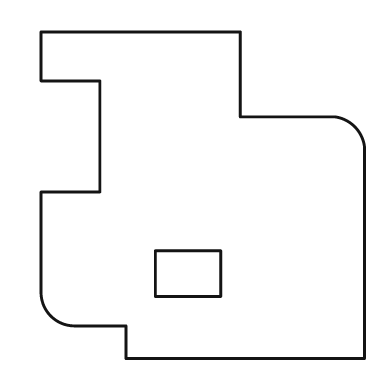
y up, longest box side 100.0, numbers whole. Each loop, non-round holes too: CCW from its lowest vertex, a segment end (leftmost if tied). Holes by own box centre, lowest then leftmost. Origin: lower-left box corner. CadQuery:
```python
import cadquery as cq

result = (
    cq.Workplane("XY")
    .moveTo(26.0, 0.0)
    .lineTo(99.0, 0.0)
    .lineTo(99.0, 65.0)
    .threePointArc((96.0, 71.0), (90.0, 74.0))
    .lineTo(61.0, 74.0)
    .lineTo(61.0, 100.0)
    .lineTo(0.0, 100.0)
    .lineTo(0.0, 85.0)
    .lineTo(18.0, 85.0)
    .lineTo(18.0, 51.0)
    .lineTo(0.0, 51.0)
    .lineTo(0.0, 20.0)
    .threePointArc((3.0, 13.0), (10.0, 10.0))
    .lineTo(26.0, 10.0)
    .close()
    .moveTo(35.0, 19.0)
    .lineTo(55.0, 19.0)
    .lineTo(55.0, 33.0)
    .lineTo(35.0, 33.0)
    .close()
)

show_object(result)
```